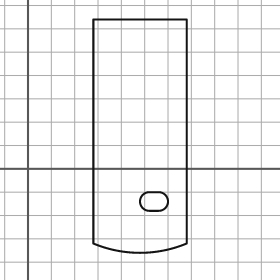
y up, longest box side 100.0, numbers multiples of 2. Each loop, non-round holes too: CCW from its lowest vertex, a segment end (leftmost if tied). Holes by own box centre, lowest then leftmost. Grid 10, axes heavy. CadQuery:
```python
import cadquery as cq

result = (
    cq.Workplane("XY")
    .moveTo(28.0, -32.0)
    .threePointArc((48.0, -36.0), (68.0, -32.0))
    .lineTo(68.0, 64.0)
    .lineTo(28.0, 64.0)
    .close()
    .moveTo(52.0, -18.0)
    .lineTo(56.0, -18.0)
    .threePointArc((60.0, -14.0), (56.0, -10.0))
    .lineTo(52.0, -10.0)
    .threePointArc((48.0, -14.0), (52.0, -18.0))
    .close()
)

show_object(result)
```